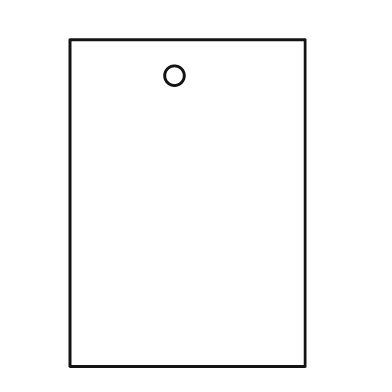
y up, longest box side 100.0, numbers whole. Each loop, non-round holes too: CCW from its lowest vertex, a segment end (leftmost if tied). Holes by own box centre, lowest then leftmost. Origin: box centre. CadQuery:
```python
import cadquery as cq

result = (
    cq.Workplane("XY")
    .moveTo(-36.0, -50.0)
    .lineTo(36.0, -50.0)
    .lineTo(36.0, 50.0)
    .lineTo(-36.0, 50.0)
    .close()
    .moveTo(-4.0, 39.0)
    .circle(3.0)
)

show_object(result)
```